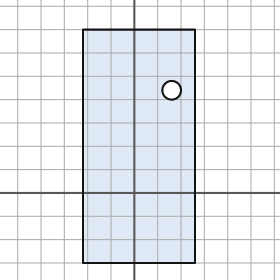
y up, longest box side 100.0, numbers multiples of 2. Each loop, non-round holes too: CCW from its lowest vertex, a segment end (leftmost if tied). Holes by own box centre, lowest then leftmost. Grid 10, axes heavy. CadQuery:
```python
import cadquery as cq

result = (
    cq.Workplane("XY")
    .moveTo(-22.0, -30.0)
    .lineTo(26.0, -30.0)
    .lineTo(26.0, 70.0)
    .lineTo(-22.0, 70.0)
    .close()
    .moveTo(16.0, 44.0)
    .circle(4.0)
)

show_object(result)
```